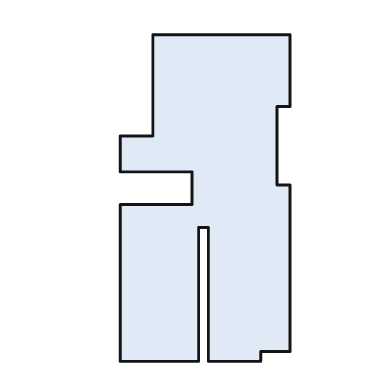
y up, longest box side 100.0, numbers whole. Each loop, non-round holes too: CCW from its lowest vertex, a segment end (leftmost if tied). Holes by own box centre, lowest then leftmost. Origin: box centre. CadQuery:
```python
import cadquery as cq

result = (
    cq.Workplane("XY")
    .moveTo(-26.0, -50.0)
    .lineTo(-2.0, -50.0)
    .lineTo(-2.0, -9.0)
    .lineTo(1.0, -9.0)
    .lineTo(1.0, -50.0)
    .lineTo(17.0, -50.0)
    .lineTo(17.0, -47.0)
    .lineTo(26.0, -47.0)
    .lineTo(26.0, 4.0)
    .lineTo(22.0, 4.0)
    .lineTo(22.0, 28.0)
    .lineTo(26.0, 28.0)
    .lineTo(26.0, 50.0)
    .lineTo(-16.0, 50.0)
    .lineTo(-16.0, 19.0)
    .lineTo(-26.0, 19.0)
    .lineTo(-26.0, 8.0)
    .lineTo(-4.0, 8.0)
    .lineTo(-4.0, -2.0)
    .lineTo(-26.0, -2.0)
    .close()
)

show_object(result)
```